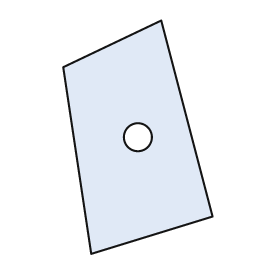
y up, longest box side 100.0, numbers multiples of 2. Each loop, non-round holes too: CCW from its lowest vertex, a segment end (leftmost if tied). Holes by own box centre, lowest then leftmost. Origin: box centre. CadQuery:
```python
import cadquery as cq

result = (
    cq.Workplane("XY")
    .moveTo(-20.0, -50.0)
    .lineTo(32.0, -34.0)
    .lineTo(10.0, 50.0)
    .lineTo(-32.0, 30.0)
    .close()
    .moveTo(0.0, 0.0)
    .circle(6.0)
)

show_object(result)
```